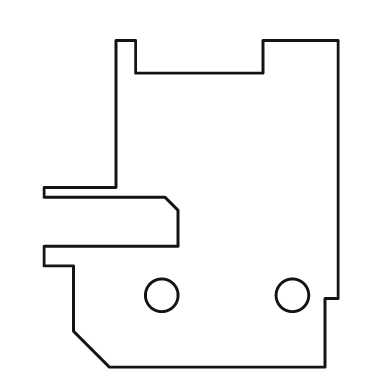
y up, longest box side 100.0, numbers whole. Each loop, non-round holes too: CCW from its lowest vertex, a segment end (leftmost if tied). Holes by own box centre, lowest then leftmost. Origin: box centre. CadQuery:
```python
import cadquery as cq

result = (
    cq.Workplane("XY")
    .moveTo(-25.0, -50.0)
    .lineTo(41.0, -50.0)
    .lineTo(41.0, -29.0)
    .lineTo(45.0, -29.0)
    .lineTo(45.0, 50.0)
    .lineTo(22.0, 50.0)
    .lineTo(22.0, 40.0)
    .lineTo(-17.0, 40.0)
    .lineTo(-17.0, 50.0)
    .lineTo(-23.0, 50.0)
    .lineTo(-23.0, 5.0)
    .lineTo(-45.0, 5.0)
    .lineTo(-45.0, 2.0)
    .lineTo(-8.0, 2.0)
    .lineTo(-4.0, -2.0)
    .lineTo(-4.0, -13.0)
    .lineTo(-45.0, -13.0)
    .lineTo(-45.0, -19.0)
    .lineTo(-36.0, -19.0)
    .lineTo(-36.0, -39.0)
    .close()
    .moveTo(-9.0, -28.0)
    .circle(5.0)
    .moveTo(31.0, -28.0)
    .circle(5.0)
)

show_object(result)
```